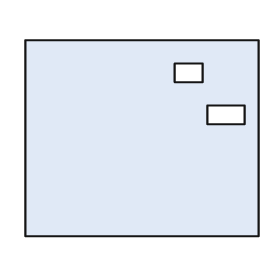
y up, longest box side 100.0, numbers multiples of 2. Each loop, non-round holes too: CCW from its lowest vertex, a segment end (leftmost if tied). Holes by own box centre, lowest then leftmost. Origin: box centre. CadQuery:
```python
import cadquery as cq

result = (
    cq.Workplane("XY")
    .moveTo(-50.0, -42.0)
    .lineTo(50.0, -42.0)
    .lineTo(50.0, 42.0)
    .lineTo(-50.0, 42.0)
    .close()
    .moveTo(28.0, 6.0)
    .lineTo(44.0, 6.0)
    .lineTo(44.0, 14.0)
    .lineTo(28.0, 14.0)
    .close()
    .moveTo(14.0, 24.0)
    .lineTo(26.0, 24.0)
    .lineTo(26.0, 32.0)
    .lineTo(14.0, 32.0)
    .close()
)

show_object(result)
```